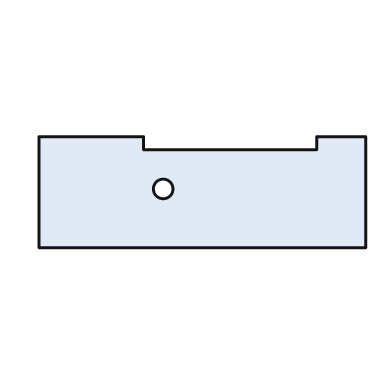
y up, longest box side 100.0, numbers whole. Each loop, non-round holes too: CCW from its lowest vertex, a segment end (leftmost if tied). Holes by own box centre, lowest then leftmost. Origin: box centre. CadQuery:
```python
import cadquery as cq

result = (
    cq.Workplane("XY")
    .moveTo(-50.0, -17.0)
    .lineTo(50.0, -17.0)
    .lineTo(50.0, 17.0)
    .lineTo(35.0, 17.0)
    .lineTo(35.0, 13.0)
    .lineTo(-18.0, 13.0)
    .lineTo(-18.0, 17.0)
    .lineTo(-50.0, 17.0)
    .close()
    .moveTo(-12.0, 1.0)
    .circle(3.0)
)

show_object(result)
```